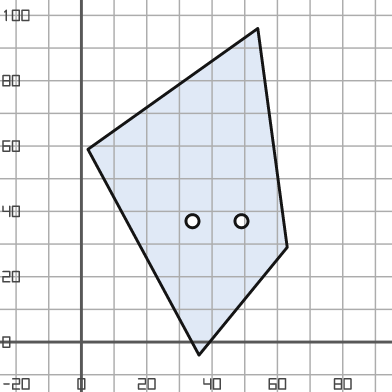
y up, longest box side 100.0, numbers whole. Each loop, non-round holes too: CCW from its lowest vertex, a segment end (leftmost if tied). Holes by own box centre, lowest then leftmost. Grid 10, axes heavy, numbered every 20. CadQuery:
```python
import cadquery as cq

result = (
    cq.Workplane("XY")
    .moveTo(36.0, -4.0)
    .lineTo(63.0, 29.0)
    .lineTo(54.0, 96.0)
    .lineTo(2.0, 59.0)
    .close()
    .moveTo(34.0, 37.0)
    .circle(2.0)
    .moveTo(49.0, 37.0)
    .circle(2.0)
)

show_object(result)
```